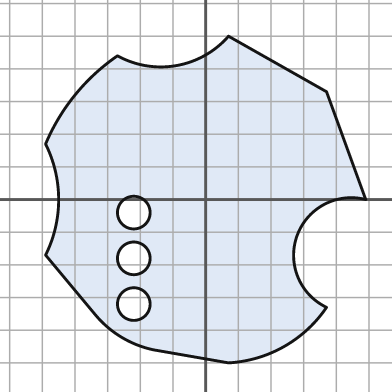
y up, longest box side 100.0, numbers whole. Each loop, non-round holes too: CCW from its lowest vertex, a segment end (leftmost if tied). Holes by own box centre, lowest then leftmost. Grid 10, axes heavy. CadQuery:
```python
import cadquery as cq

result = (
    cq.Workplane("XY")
    .moveTo(7.0, -50.0)
    .threePointArc((24.0, -45.0), (37.0, -33.0))
    .threePointArc((28.0, -11.0), (49.0, 0.0))
    .lineTo(37.0, 33.0)
    .lineTo(7.0, 50.0)
    .threePointArc((-9.0, 41.0), (-27.0, 44.0))
    .threePointArc((-40.0, 32.0), (-49.0, 17.0))
    .threePointArc((-45.0, 0.0), (-49.0, -17.0))
    .lineTo(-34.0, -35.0)
    .threePointArc((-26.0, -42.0), (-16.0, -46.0))
    .close()
    .moveTo(-22.0, -32.0)
    .circle(5.0)
    .moveTo(-22.0, -18.0)
    .circle(5.0)
    .moveTo(-22.0, -4.0)
    .circle(5.0)
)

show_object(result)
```